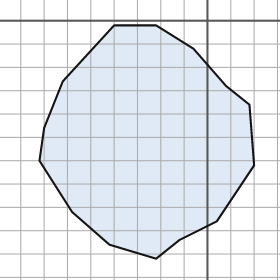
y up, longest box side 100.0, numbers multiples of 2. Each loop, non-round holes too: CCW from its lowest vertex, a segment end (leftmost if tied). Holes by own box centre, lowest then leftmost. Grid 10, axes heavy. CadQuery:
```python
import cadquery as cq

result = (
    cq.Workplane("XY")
    .moveTo(-22.0, -102.0)
    .lineTo(-12.0, -94.0)
    .lineTo(4.0, -86.0)
    .lineTo(20.0, -62.0)
    .lineTo(18.0, -36.0)
    .lineTo(8.0, -28.0)
    .lineTo(-6.0, -12.0)
    .lineTo(-22.0, -2.0)
    .lineTo(-40.0, -2.0)
    .lineTo(-62.0, -26.0)
    .lineTo(-70.0, -46.0)
    .lineTo(-72.0, -60.0)
    .lineTo(-58.0, -82.0)
    .lineTo(-42.0, -96.0)
    .close()
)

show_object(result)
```